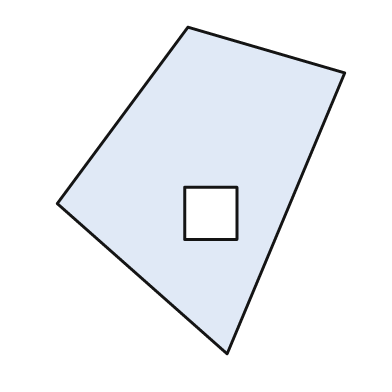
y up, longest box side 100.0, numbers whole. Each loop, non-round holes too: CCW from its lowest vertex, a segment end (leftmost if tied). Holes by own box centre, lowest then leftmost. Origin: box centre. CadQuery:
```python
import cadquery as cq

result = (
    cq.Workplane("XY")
    .moveTo(8.0, -50.0)
    .lineTo(44.0, 36.0)
    .lineTo(-4.0, 50.0)
    .lineTo(-44.0, -4.0)
    .close()
    .moveTo(-5.0, -15.0)
    .lineTo(11.0, -15.0)
    .lineTo(11.0, 1.0)
    .lineTo(-5.0, 1.0)
    .close()
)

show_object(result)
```